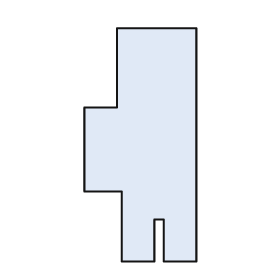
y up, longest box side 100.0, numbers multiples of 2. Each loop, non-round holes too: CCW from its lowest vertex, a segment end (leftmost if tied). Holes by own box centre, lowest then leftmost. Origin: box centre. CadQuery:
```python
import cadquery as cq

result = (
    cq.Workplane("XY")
    .moveTo(-8.0, -50.0)
    .lineTo(6.0, -50.0)
    .lineTo(6.0, -32.0)
    .lineTo(10.0, -32.0)
    .lineTo(10.0, -50.0)
    .lineTo(24.0, -50.0)
    .lineTo(24.0, 50.0)
    .lineTo(-10.0, 50.0)
    .lineTo(-10.0, 16.0)
    .lineTo(-24.0, 16.0)
    .lineTo(-24.0, -20.0)
    .lineTo(-8.0, -20.0)
    .close()
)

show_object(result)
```